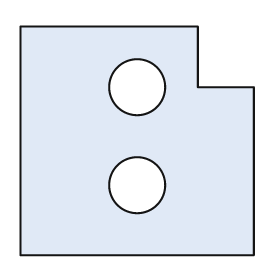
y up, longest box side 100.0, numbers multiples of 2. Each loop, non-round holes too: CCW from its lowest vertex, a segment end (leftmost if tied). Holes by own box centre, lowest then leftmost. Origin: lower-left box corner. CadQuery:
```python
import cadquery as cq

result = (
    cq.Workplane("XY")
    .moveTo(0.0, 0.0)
    .lineTo(100.0, 0.0)
    .lineTo(100.0, 72.0)
    .lineTo(76.0, 72.0)
    .lineTo(76.0, 98.0)
    .lineTo(0.0, 98.0)
    .close()
    .moveTo(50.0, 30.0)
    .circle(12.0)
    .moveTo(50.0, 72.0)
    .circle(12.0)
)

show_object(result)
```